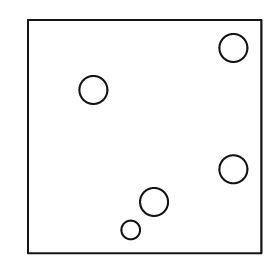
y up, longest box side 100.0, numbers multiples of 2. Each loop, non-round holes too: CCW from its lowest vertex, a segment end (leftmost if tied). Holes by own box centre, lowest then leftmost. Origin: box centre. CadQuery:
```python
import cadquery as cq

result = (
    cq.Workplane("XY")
    .moveTo(-50.0, -50.0)
    .lineTo(50.0, -50.0)
    .lineTo(50.0, 50.0)
    .lineTo(-50.0, 50.0)
    .close()
    .moveTo(-6.0, -40.0)
    .circle(4.0)
    .moveTo(4.0, -28.0)
    .circle(6.0)
    .moveTo(38.0, -14.0)
    .circle(6.0)
    .moveTo(-22.0, 20.0)
    .circle(6.0)
    .moveTo(38.0, 38.0)
    .circle(6.0)
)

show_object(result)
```